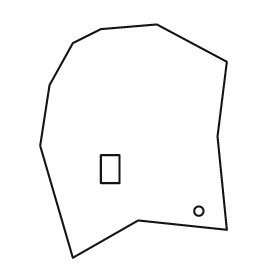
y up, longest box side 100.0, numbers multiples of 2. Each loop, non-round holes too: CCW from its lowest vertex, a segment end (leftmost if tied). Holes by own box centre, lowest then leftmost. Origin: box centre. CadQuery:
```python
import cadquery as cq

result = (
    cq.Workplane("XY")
    .moveTo(-26.0, -50.0)
    .lineTo(2.0, -34.0)
    .lineTo(40.0, -38.0)
    .lineTo(36.0, 2.0)
    .lineTo(40.0, 34.0)
    .lineTo(10.0, 50.0)
    .lineTo(-14.0, 48.0)
    .lineTo(-26.0, 42.0)
    .lineTo(-36.0, 24.0)
    .lineTo(-40.0, -2.0)
    .close()
    .moveTo(28.0, -30.0)
    .circle(2.0)
    .moveTo(-14.0, -18.0)
    .lineTo(-6.0, -18.0)
    .lineTo(-6.0, -6.0)
    .lineTo(-14.0, -6.0)
    .close()
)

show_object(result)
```